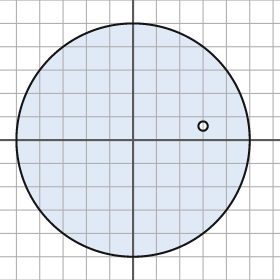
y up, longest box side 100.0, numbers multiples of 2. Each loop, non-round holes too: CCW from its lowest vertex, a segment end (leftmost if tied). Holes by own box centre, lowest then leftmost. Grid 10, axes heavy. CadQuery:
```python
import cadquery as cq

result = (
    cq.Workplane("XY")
    .moveTo(0.0, 0.0)
    .circle(50.0)
    .moveTo(30.0, 6.0)
    .circle(2.0)
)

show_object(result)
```